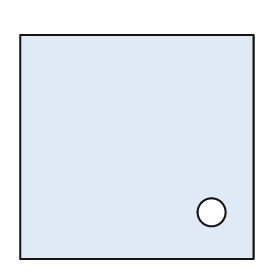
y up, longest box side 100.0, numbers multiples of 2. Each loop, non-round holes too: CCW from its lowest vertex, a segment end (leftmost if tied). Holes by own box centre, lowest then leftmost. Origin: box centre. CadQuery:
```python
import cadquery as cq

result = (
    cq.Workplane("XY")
    .moveTo(-50.0, -48.0)
    .lineTo(50.0, -48.0)
    .lineTo(50.0, 48.0)
    .lineTo(-50.0, 48.0)
    .close()
    .moveTo(32.0, -28.0)
    .circle(6.0)
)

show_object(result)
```